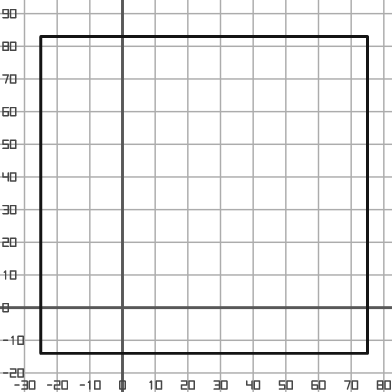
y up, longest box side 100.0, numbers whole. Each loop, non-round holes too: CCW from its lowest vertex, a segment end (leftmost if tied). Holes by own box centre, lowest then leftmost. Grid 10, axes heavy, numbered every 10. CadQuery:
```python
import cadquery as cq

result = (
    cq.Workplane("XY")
    .moveTo(-25.0, -14.0)
    .lineTo(75.0, -14.0)
    .lineTo(75.0, 83.0)
    .lineTo(-25.0, 83.0)
    .close()
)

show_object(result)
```